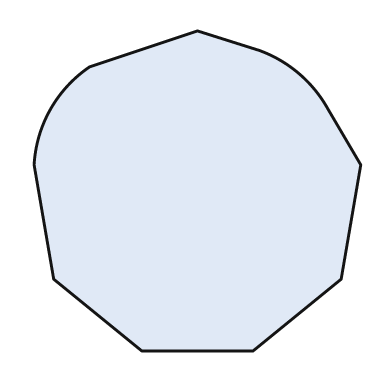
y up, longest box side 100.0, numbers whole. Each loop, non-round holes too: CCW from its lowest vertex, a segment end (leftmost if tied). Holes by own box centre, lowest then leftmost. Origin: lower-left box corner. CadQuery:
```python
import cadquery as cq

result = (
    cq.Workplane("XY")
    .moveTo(33.0, 0.0)
    .lineTo(67.0, 0.0)
    .lineTo(94.0, 22.0)
    .lineTo(100.0, 57.0)
    .lineTo(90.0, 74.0)
    .threePointArc((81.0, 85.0), (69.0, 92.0))
    .lineTo(50.0, 98.0)
    .lineTo(17.0, 87.0)
    .threePointArc((5.0, 74.0), (0.0, 57.0))
    .lineTo(6.0, 22.0)
    .close()
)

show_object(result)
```